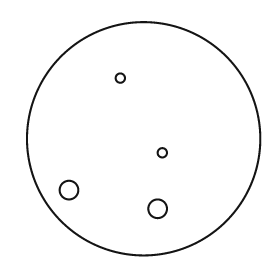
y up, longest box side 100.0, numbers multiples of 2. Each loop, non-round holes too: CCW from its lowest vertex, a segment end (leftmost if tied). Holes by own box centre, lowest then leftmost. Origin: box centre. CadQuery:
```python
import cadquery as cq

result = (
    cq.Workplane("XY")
    .moveTo(0.0, 0.0)
    .circle(50.0)
    .moveTo(6.0, -30.0)
    .circle(4.0)
    .moveTo(-32.0, -22.0)
    .circle(4.0)
    .moveTo(8.0, -6.0)
    .circle(2.0)
    .moveTo(-10.0, 26.0)
    .circle(2.0)
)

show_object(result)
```